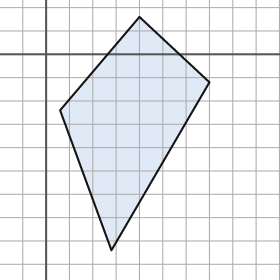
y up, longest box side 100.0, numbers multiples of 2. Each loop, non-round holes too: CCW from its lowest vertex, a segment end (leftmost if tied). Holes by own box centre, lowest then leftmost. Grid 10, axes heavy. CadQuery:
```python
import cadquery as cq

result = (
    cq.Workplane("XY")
    .moveTo(28.0, -84.0)
    .lineTo(70.0, -12.0)
    .lineTo(40.0, 16.0)
    .lineTo(6.0, -24.0)
    .close()
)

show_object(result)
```